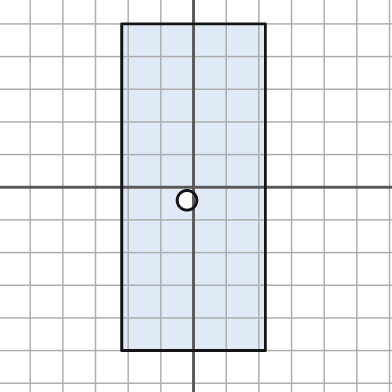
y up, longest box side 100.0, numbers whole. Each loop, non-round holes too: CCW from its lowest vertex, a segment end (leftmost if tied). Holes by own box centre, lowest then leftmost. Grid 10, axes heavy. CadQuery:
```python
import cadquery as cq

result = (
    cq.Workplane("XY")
    .moveTo(-22.0, -50.0)
    .lineTo(22.0, -50.0)
    .lineTo(22.0, 50.0)
    .lineTo(-22.0, 50.0)
    .close()
    .moveTo(-2.0, -4.0)
    .circle(3.0)
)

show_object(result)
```